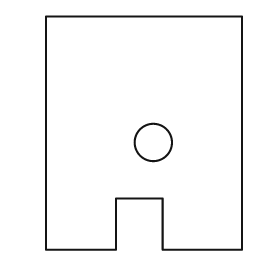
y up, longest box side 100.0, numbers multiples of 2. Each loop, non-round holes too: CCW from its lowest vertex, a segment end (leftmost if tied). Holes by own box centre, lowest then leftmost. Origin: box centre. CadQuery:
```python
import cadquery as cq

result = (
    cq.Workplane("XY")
    .moveTo(-42.0, -50.0)
    .lineTo(-12.0, -50.0)
    .lineTo(-12.0, -28.0)
    .lineTo(8.0, -28.0)
    .lineTo(8.0, -50.0)
    .lineTo(42.0, -50.0)
    .lineTo(42.0, 50.0)
    .lineTo(-42.0, 50.0)
    .close()
    .moveTo(4.0, -4.0)
    .circle(8.0)
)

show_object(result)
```